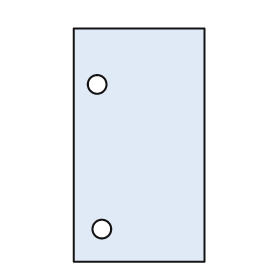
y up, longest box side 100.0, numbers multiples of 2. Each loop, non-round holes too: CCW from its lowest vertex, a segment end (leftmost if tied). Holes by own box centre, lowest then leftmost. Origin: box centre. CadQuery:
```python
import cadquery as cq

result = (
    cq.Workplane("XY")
    .moveTo(-28.0, -50.0)
    .lineTo(28.0, -50.0)
    .lineTo(28.0, 50.0)
    .lineTo(-28.0, 50.0)
    .close()
    .moveTo(-16.0, -36.0)
    .circle(4.0)
    .moveTo(-18.0, 26.0)
    .circle(4.0)
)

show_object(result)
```